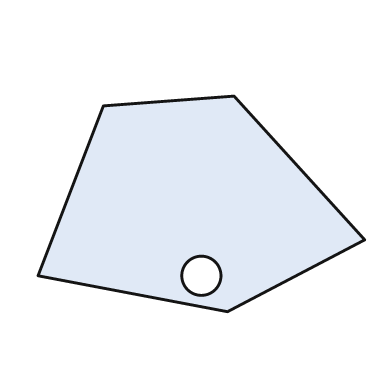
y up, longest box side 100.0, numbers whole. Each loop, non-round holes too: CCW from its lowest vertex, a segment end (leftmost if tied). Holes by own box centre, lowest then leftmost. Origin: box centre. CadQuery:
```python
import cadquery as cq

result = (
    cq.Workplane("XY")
    .moveTo(8.0, -33.0)
    .lineTo(50.0, -11.0)
    .lineTo(10.0, 33.0)
    .lineTo(-30.0, 30.0)
    .lineTo(-50.0, -22.0)
    .close()
    .moveTo(0.0, -22.0)
    .circle(6.0)
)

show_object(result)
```